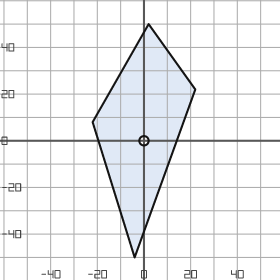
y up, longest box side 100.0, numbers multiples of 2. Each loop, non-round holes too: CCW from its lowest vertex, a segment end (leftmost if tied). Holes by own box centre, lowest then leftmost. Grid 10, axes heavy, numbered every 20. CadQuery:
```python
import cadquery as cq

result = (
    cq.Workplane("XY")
    .moveTo(-4.0, -50.0)
    .lineTo(22.0, 22.0)
    .lineTo(2.0, 50.0)
    .lineTo(-22.0, 8.0)
    .close()
    .moveTo(0.0, 0.0)
    .circle(2.0)
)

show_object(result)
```